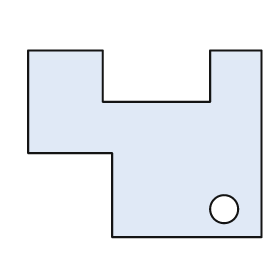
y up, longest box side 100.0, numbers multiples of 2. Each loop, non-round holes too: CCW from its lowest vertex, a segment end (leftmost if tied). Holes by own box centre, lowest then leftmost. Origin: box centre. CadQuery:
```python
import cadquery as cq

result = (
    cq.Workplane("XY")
    .moveTo(-14.0, -40.0)
    .lineTo(50.0, -40.0)
    .lineTo(50.0, 40.0)
    .lineTo(28.0, 40.0)
    .lineTo(28.0, 18.0)
    .lineTo(-18.0, 18.0)
    .lineTo(-18.0, 40.0)
    .lineTo(-50.0, 40.0)
    .lineTo(-50.0, -4.0)
    .lineTo(-14.0, -4.0)
    .close()
    .moveTo(34.0, -28.0)
    .circle(6.0)
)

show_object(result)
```